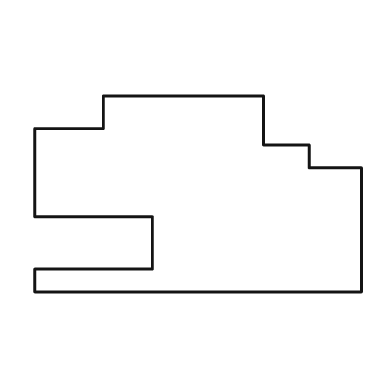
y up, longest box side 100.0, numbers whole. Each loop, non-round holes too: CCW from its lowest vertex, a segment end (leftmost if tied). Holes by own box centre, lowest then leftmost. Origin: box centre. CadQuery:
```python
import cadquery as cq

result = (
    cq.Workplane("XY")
    .moveTo(-50.0, -30.0)
    .lineTo(50.0, -30.0)
    .lineTo(50.0, 8.0)
    .lineTo(34.0, 8.0)
    .lineTo(34.0, 15.0)
    .lineTo(20.0, 15.0)
    .lineTo(20.0, 30.0)
    .lineTo(-29.0, 30.0)
    .lineTo(-29.0, 20.0)
    .lineTo(-50.0, 20.0)
    .lineTo(-50.0, -7.0)
    .lineTo(-14.0, -7.0)
    .lineTo(-14.0, -23.0)
    .lineTo(-50.0, -23.0)
    .close()
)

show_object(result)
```